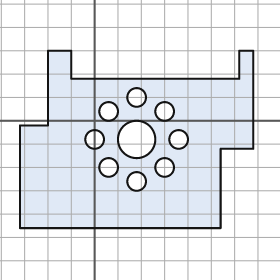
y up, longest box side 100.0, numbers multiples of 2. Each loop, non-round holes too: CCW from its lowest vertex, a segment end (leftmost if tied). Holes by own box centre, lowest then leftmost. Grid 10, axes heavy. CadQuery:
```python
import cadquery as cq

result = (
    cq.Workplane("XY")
    .moveTo(-32.0, -46.0)
    .lineTo(54.0, -46.0)
    .lineTo(54.0, -12.0)
    .lineTo(68.0, -12.0)
    .lineTo(68.0, 30.0)
    .lineTo(62.0, 30.0)
    .lineTo(62.0, 18.0)
    .lineTo(-10.0, 18.0)
    .lineTo(-10.0, 30.0)
    .lineTo(-20.0, 30.0)
    .lineTo(-20.0, -2.0)
    .lineTo(-32.0, -2.0)
    .close()
    .moveTo(18.0, -26.0)
    .circle(4.0)
    .moveTo(6.0, -20.0)
    .circle(4.0)
    .moveTo(30.0, -20.0)
    .circle(4.0)
    .moveTo(0.0, -8.0)
    .circle(4.0)
    .moveTo(18.0, -8.0)
    .circle(8.0)
    .moveTo(36.0, -8.0)
    .circle(4.0)
    .moveTo(6.0, 4.0)
    .circle(4.0)
    .moveTo(30.0, 4.0)
    .circle(4.0)
    .moveTo(18.0, 10.0)
    .circle(4.0)
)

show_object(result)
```